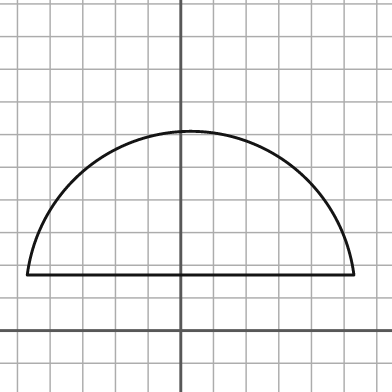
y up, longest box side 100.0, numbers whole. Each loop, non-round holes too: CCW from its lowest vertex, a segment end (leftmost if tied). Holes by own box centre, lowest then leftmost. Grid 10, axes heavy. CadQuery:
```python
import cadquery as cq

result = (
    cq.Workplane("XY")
    .moveTo(-47.0, 17.0)
    .lineTo(53.0, 17.0)
    .threePointArc((3.0, 61.0), (-47.0, 17.0))
    .close()
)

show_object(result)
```